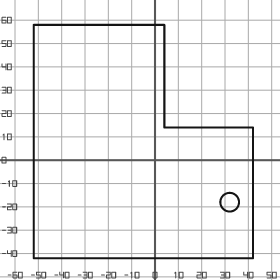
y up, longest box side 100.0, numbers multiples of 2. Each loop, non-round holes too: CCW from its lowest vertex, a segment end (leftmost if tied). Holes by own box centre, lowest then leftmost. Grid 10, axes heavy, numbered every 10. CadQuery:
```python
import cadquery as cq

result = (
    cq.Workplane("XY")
    .moveTo(-52.0, -42.0)
    .lineTo(42.0, -42.0)
    .lineTo(42.0, 14.0)
    .lineTo(4.0, 14.0)
    .lineTo(4.0, 58.0)
    .lineTo(-52.0, 58.0)
    .close()
    .moveTo(32.0, -18.0)
    .circle(4.0)
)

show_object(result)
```